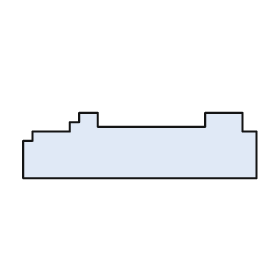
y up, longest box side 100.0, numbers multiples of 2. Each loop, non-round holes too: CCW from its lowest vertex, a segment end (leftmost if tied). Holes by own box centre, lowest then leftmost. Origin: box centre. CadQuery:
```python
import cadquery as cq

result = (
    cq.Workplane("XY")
    .moveTo(-50.0, -14.0)
    .lineTo(50.0, -14.0)
    .lineTo(50.0, 6.0)
    .lineTo(44.0, 6.0)
    .lineTo(44.0, 14.0)
    .lineTo(28.0, 14.0)
    .lineTo(28.0, 8.0)
    .lineTo(-18.0, 8.0)
    .lineTo(-18.0, 14.0)
    .lineTo(-26.0, 14.0)
    .lineTo(-26.0, 10.0)
    .lineTo(-30.0, 10.0)
    .lineTo(-30.0, 6.0)
    .lineTo(-46.0, 6.0)
    .lineTo(-46.0, 2.0)
    .lineTo(-50.0, 2.0)
    .close()
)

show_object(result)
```